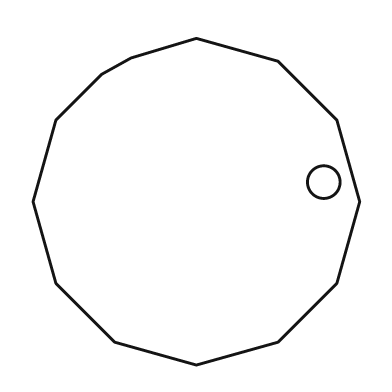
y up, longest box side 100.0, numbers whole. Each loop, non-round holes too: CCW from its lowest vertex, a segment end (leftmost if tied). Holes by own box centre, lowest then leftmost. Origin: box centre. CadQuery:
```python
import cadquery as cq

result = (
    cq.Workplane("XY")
    .moveTo(0.0, -50.0)
    .lineTo(25.0, -43.0)
    .lineTo(43.0, -25.0)
    .lineTo(50.0, 0.0)
    .lineTo(43.0, 25.0)
    .lineTo(25.0, 43.0)
    .lineTo(0.0, 50.0)
    .lineTo(-20.0, 44.0)
    .lineTo(-29.0, 39.0)
    .lineTo(-43.0, 25.0)
    .lineTo(-50.0, 0.0)
    .lineTo(-43.0, -25.0)
    .lineTo(-25.0, -43.0)
    .close()
    .moveTo(39.0, 6.0)
    .circle(5.0)
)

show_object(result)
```